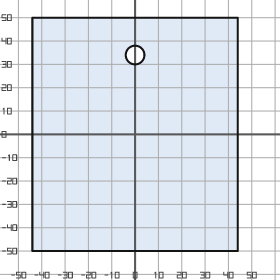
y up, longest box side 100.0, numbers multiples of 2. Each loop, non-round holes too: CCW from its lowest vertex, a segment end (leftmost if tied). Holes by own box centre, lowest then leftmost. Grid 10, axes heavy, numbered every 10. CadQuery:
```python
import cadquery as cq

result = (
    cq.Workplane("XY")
    .moveTo(-44.0, -50.0)
    .lineTo(44.0, -50.0)
    .lineTo(44.0, 50.0)
    .lineTo(-44.0, 50.0)
    .close()
    .moveTo(0.0, 34.0)
    .circle(4.0)
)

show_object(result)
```